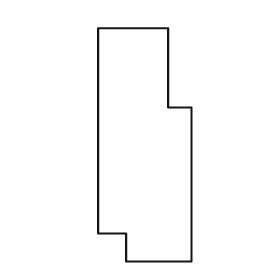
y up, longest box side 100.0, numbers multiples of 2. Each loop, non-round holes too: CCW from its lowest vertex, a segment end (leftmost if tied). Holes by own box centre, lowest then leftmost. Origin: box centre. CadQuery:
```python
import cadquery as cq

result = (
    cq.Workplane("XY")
    .moveTo(-8.0, -50.0)
    .lineTo(20.0, -50.0)
    .lineTo(20.0, 16.0)
    .lineTo(10.0, 16.0)
    .lineTo(10.0, 50.0)
    .lineTo(-20.0, 50.0)
    .lineTo(-20.0, -38.0)
    .lineTo(-8.0, -38.0)
    .close()
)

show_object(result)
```